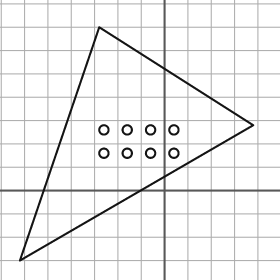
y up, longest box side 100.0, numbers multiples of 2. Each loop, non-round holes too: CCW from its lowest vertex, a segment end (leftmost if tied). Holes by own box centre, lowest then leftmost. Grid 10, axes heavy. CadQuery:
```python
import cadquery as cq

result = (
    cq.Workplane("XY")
    .moveTo(-62.0, -30.0)
    .lineTo(38.0, 28.0)
    .lineTo(-28.0, 70.0)
    .close()
    .moveTo(-26.0, 16.0)
    .circle(2.0)
    .moveTo(-16.0, 16.0)
    .circle(2.0)
    .moveTo(-6.0, 16.0)
    .circle(2.0)
    .moveTo(4.0, 16.0)
    .circle(2.0)
    .moveTo(-26.0, 26.0)
    .circle(2.0)
    .moveTo(-16.0, 26.0)
    .circle(2.0)
    .moveTo(-6.0, 26.0)
    .circle(2.0)
    .moveTo(4.0, 26.0)
    .circle(2.0)
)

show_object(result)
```